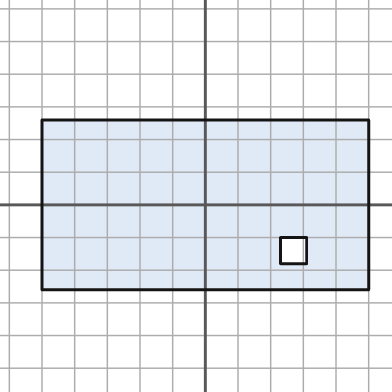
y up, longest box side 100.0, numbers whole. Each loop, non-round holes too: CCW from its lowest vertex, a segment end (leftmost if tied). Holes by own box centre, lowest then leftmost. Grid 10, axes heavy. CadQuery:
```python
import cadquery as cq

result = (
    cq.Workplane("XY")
    .moveTo(-50.0, -26.0)
    .lineTo(50.0, -26.0)
    .lineTo(50.0, 26.0)
    .lineTo(-50.0, 26.0)
    .close()
    .moveTo(23.0, -18.0)
    .lineTo(31.0, -18.0)
    .lineTo(31.0, -10.0)
    .lineTo(23.0, -10.0)
    .close()
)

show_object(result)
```